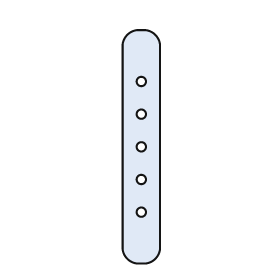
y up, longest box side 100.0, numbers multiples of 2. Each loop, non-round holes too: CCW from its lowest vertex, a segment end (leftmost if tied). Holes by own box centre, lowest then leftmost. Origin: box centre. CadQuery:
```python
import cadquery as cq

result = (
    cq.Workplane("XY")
    .moveTo(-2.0, -50.0)
    .lineTo(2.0, -50.0)
    .threePointArc((6.0, -48.0), (8.0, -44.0))
    .lineTo(8.0, 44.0)
    .threePointArc((6.0, 48.0), (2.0, 50.0))
    .lineTo(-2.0, 50.0)
    .threePointArc((-6.0, 48.0), (-8.0, 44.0))
    .lineTo(-8.0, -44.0)
    .threePointArc((-6.0, -48.0), (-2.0, -50.0))
    .close()
    .moveTo(0.0, -28.0)
    .circle(2.0)
    .moveTo(0.0, -14.0)
    .circle(2.0)
    .moveTo(0.0, 0.0)
    .circle(2.0)
    .moveTo(0.0, 14.0)
    .circle(2.0)
    .moveTo(0.0, 28.0)
    .circle(2.0)
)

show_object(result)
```